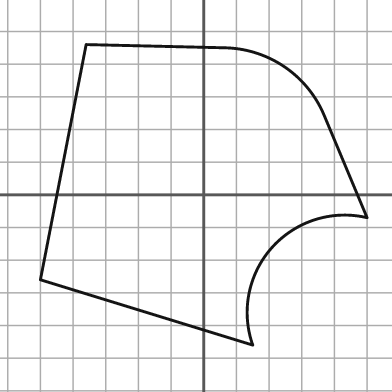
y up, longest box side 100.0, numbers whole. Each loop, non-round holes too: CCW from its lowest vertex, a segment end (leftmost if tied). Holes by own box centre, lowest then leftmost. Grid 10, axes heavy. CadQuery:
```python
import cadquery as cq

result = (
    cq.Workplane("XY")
    .moveTo(15.0, -46.0)
    .threePointArc((21.0, -16.0), (50.0, -7.0))
    .lineTo(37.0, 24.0)
    .threePointArc((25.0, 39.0), (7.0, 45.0))
    .lineTo(-36.0, 46.0)
    .lineTo(-50.0, -26.0)
    .close()
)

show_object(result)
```